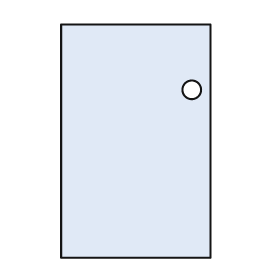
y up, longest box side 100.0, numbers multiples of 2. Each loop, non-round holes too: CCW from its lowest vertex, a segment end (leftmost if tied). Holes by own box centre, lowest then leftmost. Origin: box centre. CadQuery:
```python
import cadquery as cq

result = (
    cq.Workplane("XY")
    .moveTo(-32.0, -50.0)
    .lineTo(32.0, -50.0)
    .lineTo(32.0, 50.0)
    .lineTo(-32.0, 50.0)
    .close()
    .moveTo(24.0, 22.0)
    .circle(4.0)
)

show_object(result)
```